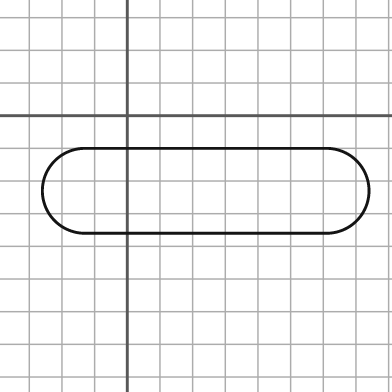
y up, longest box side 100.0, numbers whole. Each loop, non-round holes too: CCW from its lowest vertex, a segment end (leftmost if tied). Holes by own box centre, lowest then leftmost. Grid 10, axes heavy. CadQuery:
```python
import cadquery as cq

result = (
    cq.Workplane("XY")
    .moveTo(-13.0, -36.0)
    .lineTo(61.0, -36.0)
    .threePointArc((74.0, -23.0), (61.0, -10.0))
    .lineTo(-13.0, -10.0)
    .threePointArc((-26.0, -23.0), (-13.0, -36.0))
    .close()
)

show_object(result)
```